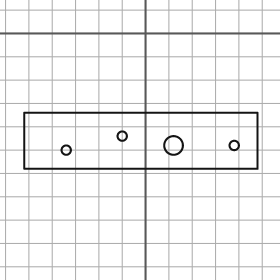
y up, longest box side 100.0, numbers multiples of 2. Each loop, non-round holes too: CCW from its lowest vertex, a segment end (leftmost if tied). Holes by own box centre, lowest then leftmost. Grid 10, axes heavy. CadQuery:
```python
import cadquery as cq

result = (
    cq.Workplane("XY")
    .moveTo(-52.0, -58.0)
    .lineTo(48.0, -58.0)
    .lineTo(48.0, -34.0)
    .lineTo(-52.0, -34.0)
    .close()
    .moveTo(-34.0, -50.0)
    .circle(2.0)
    .moveTo(12.0, -48.0)
    .circle(4.0)
    .moveTo(38.0, -48.0)
    .circle(2.0)
    .moveTo(-10.0, -44.0)
    .circle(2.0)
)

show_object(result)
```